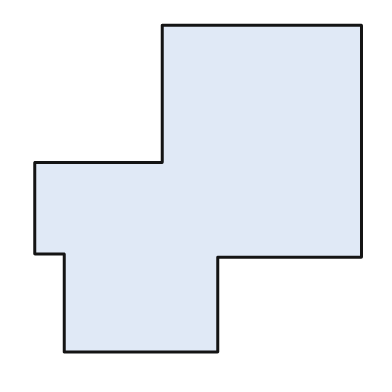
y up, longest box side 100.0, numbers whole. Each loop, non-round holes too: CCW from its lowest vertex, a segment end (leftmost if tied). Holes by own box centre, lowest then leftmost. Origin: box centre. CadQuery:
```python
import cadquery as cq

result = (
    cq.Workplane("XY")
    .moveTo(-41.0, -50.0)
    .lineTo(6.0, -50.0)
    .lineTo(6.0, -21.0)
    .lineTo(50.0, -21.0)
    .lineTo(50.0, 50.0)
    .lineTo(-11.0, 50.0)
    .lineTo(-11.0, 8.0)
    .lineTo(-50.0, 8.0)
    .lineTo(-50.0, -20.0)
    .lineTo(-41.0, -20.0)
    .close()
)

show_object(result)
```